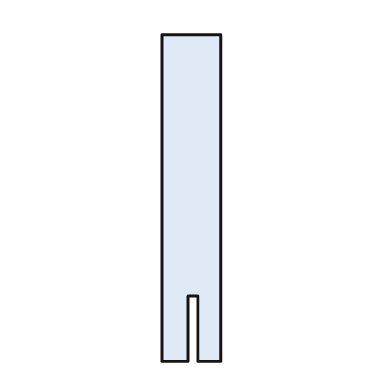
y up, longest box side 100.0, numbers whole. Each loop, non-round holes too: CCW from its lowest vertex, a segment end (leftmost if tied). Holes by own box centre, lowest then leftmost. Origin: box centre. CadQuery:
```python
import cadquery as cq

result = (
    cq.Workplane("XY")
    .moveTo(-9.0, -50.0)
    .lineTo(-1.0, -50.0)
    .lineTo(-1.0, -30.0)
    .lineTo(2.0, -30.0)
    .lineTo(2.0, -50.0)
    .lineTo(9.0, -50.0)
    .lineTo(9.0, 50.0)
    .lineTo(-9.0, 50.0)
    .close()
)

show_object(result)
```